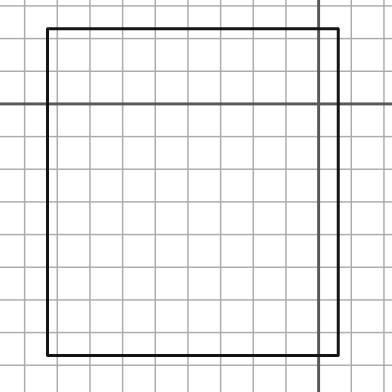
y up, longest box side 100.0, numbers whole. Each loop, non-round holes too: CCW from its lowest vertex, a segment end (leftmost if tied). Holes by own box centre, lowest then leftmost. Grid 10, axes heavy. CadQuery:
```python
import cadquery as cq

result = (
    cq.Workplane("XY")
    .moveTo(-83.0, -77.0)
    .lineTo(6.0, -77.0)
    .lineTo(6.0, 23.0)
    .lineTo(-83.0, 23.0)
    .close()
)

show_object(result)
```